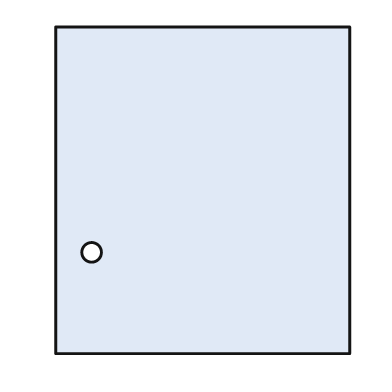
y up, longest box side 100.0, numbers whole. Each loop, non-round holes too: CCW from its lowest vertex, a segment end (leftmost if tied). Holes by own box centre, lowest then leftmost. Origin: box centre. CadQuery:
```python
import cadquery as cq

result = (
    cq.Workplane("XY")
    .moveTo(-45.0, -50.0)
    .lineTo(45.0, -50.0)
    .lineTo(45.0, 50.0)
    .lineTo(-45.0, 50.0)
    .close()
    .moveTo(-34.0, -19.0)
    .circle(3.0)
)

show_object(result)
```